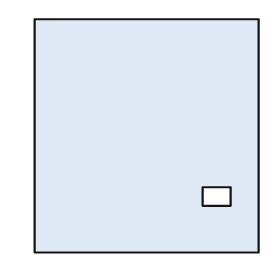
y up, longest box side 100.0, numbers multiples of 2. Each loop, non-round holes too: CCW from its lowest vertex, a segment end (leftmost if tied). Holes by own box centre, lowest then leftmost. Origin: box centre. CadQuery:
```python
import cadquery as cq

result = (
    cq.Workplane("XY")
    .moveTo(-48.0, -50.0)
    .lineTo(48.0, -50.0)
    .lineTo(48.0, 50.0)
    .lineTo(-48.0, 50.0)
    .close()
    .moveTo(24.0, -30.0)
    .lineTo(36.0, -30.0)
    .lineTo(36.0, -22.0)
    .lineTo(24.0, -22.0)
    .close()
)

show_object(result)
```